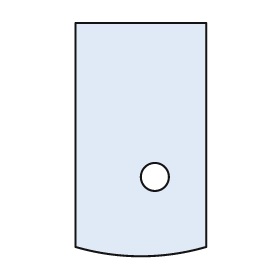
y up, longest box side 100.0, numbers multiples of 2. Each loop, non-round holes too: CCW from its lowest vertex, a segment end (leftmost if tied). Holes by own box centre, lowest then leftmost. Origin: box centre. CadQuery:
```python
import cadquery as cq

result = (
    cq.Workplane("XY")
    .moveTo(-28.0, -46.0)
    .threePointArc((0.0, -50.0), (28.0, -46.0))
    .lineTo(28.0, 50.0)
    .lineTo(-28.0, 50.0)
    .close()
    .moveTo(6.0, -16.0)
    .circle(6.0)
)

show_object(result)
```